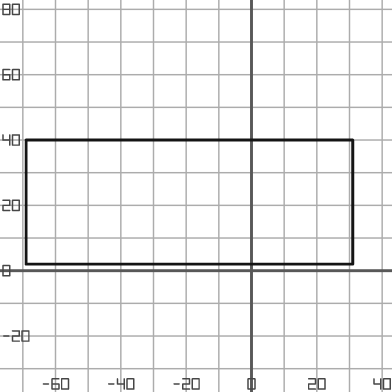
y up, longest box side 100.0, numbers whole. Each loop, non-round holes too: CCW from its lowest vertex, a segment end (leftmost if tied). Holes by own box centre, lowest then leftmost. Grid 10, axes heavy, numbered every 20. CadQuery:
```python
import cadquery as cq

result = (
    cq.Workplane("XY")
    .moveTo(-69.0, 2.0)
    .lineTo(31.0, 2.0)
    .lineTo(31.0, 40.0)
    .lineTo(-69.0, 40.0)
    .close()
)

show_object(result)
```